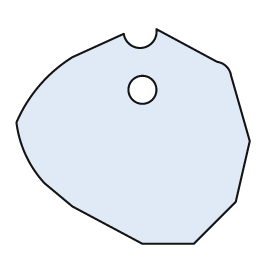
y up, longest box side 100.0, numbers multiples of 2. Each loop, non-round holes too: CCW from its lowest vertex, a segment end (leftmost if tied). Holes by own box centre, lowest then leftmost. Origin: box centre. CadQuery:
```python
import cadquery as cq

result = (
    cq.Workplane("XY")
    .moveTo(4.0, -46.0)
    .lineTo(26.0, -46.0)
    .lineTo(44.0, -28.0)
    .lineTo(50.0, -2.0)
    .lineTo(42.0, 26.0)
    .threePointArc((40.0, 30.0), (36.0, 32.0))
    .lineTo(10.0, 46.0)
    .threePointArc((4.0, 38.0), (-4.0, 44.0))
    .lineTo(-26.0, 34.0)
    .threePointArc((-40.0, 22.0), (-50.0, 6.0))
    .threePointArc((-46.0, -8.0), (-38.0, -20.0))
    .lineTo(-26.0, -30.0)
    .close()
    .moveTo(4.0, 20.0)
    .circle(6.0)
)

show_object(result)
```